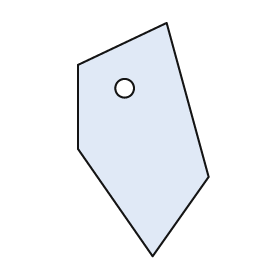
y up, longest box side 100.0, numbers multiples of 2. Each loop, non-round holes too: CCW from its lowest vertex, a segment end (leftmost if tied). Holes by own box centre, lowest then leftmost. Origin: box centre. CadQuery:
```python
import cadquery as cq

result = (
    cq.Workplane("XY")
    .moveTo(4.0, -50.0)
    .lineTo(28.0, -16.0)
    .lineTo(10.0, 50.0)
    .lineTo(-28.0, 32.0)
    .lineTo(-28.0, -4.0)
    .close()
    .moveTo(-8.0, 22.0)
    .circle(4.0)
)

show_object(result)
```